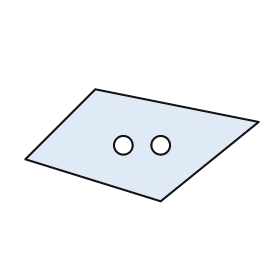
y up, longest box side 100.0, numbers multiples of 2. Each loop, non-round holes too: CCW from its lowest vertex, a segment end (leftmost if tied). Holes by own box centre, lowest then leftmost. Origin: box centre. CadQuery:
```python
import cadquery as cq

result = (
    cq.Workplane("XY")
    .moveTo(8.0, -24.0)
    .lineTo(50.0, 10.0)
    .lineTo(-20.0, 24.0)
    .lineTo(-50.0, -6.0)
    .close()
    .moveTo(-8.0, 0.0)
    .circle(4.0)
    .moveTo(8.0, 0.0)
    .circle(4.0)
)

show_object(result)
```